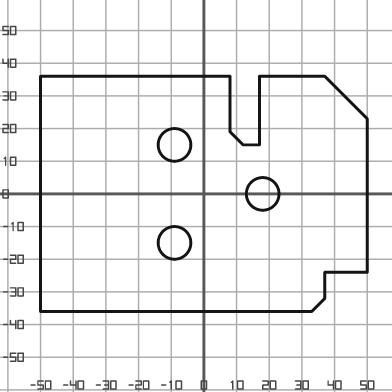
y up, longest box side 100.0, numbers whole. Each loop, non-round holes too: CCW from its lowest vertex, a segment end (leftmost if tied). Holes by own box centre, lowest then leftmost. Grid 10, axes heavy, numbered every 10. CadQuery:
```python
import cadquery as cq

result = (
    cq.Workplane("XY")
    .moveTo(-50.0, -36.0)
    .lineTo(33.0, -36.0)
    .lineTo(37.0, -32.0)
    .lineTo(37.0, -24.0)
    .lineTo(50.0, -24.0)
    .lineTo(50.0, 23.0)
    .lineTo(37.0, 36.0)
    .lineTo(17.0, 36.0)
    .lineTo(17.0, 15.0)
    .lineTo(12.0, 15.0)
    .lineTo(8.0, 19.0)
    .lineTo(8.0, 36.0)
    .lineTo(-50.0, 36.0)
    .close()
    .moveTo(-9.0, -15.0)
    .circle(5.0)
    .moveTo(18.0, 0.0)
    .circle(5.0)
    .moveTo(-9.0, 15.0)
    .circle(5.0)
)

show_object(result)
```